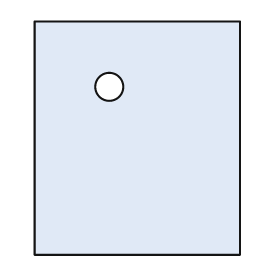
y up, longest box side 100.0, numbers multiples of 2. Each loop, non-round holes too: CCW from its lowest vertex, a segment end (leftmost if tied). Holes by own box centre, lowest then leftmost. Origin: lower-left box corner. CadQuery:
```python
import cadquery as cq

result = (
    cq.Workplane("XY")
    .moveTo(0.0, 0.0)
    .lineTo(88.0, 0.0)
    .lineTo(88.0, 100.0)
    .lineTo(0.0, 100.0)
    .close()
    .moveTo(32.0, 72.0)
    .circle(6.0)
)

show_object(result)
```